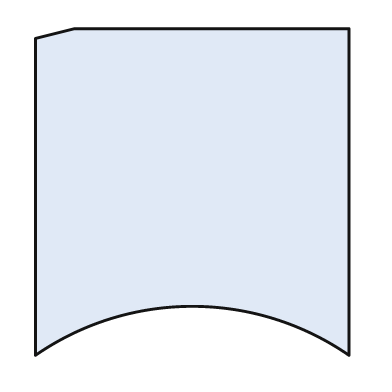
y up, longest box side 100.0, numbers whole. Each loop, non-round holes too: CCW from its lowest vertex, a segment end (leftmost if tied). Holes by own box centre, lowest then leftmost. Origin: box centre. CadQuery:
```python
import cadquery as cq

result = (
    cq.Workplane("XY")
    .moveTo(-48.0, -50.0)
    .threePointArc((0.0, -35.0), (48.0, -50.0))
    .lineTo(48.0, 50.0)
    .lineTo(-36.0, 50.0)
    .lineTo(-48.0, 47.0)
    .close()
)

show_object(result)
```